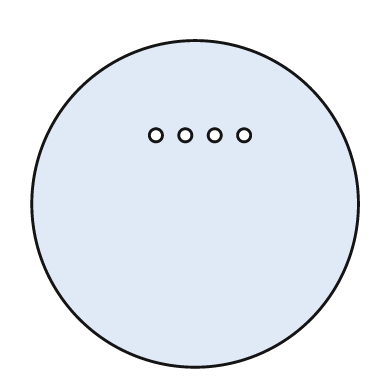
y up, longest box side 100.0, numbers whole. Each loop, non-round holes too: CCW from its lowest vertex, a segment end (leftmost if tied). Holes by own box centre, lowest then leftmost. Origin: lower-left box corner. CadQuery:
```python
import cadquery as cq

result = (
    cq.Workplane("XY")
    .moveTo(50.0, 50.0)
    .circle(50.0)
    .moveTo(38.0, 71.0)
    .circle(2.0)
    .moveTo(47.0, 71.0)
    .circle(2.0)
    .moveTo(56.0, 71.0)
    .circle(2.0)
    .moveTo(65.0, 71.0)
    .circle(2.0)
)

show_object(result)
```